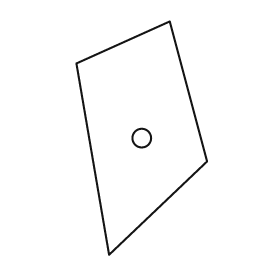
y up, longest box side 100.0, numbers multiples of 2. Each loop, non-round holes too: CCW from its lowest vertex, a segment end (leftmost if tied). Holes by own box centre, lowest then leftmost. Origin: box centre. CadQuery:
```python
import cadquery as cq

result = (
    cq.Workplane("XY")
    .moveTo(-14.0, -50.0)
    .lineTo(28.0, -10.0)
    .lineTo(12.0, 50.0)
    .lineTo(-28.0, 32.0)
    .close()
    .moveTo(0.0, 0.0)
    .circle(4.0)
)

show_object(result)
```